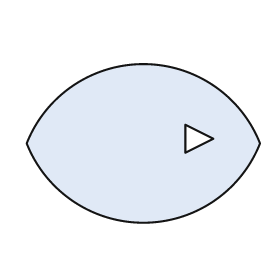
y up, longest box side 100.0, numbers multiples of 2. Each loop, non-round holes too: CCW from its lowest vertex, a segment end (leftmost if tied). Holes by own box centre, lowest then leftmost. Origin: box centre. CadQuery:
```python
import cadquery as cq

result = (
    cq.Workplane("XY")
    .moveTo(-50.0, 0.0)
    .threePointArc((0.0, -34.0), (50.0, 0.0))
    .threePointArc((0.0, 34.0), (-50.0, 0.0))
    .close()
    .moveTo(18.0, -4.0)
    .lineTo(30.0, 2.0)
    .lineTo(18.0, 8.0)
    .close()
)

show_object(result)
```